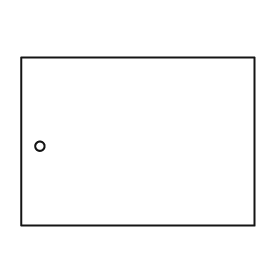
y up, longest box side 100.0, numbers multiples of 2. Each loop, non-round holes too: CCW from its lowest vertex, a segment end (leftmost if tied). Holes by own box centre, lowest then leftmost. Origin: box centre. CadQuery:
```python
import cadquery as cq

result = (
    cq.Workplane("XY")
    .moveTo(-50.0, -36.0)
    .lineTo(50.0, -36.0)
    .lineTo(50.0, 36.0)
    .lineTo(-50.0, 36.0)
    .close()
    .moveTo(-42.0, -2.0)
    .circle(2.0)
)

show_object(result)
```